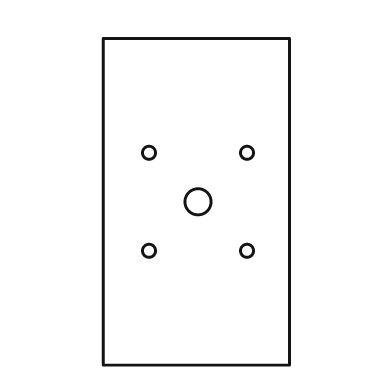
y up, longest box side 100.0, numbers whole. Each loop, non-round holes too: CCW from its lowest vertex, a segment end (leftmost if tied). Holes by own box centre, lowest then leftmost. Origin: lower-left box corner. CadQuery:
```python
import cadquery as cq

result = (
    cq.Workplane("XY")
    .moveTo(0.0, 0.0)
    .lineTo(57.0, 0.0)
    .lineTo(57.0, 100.0)
    .lineTo(0.0, 100.0)
    .close()
    .moveTo(14.0, 35.0)
    .circle(2.0)
    .moveTo(44.0, 35.0)
    .circle(2.0)
    .moveTo(29.0, 50.0)
    .circle(4.0)
    .moveTo(14.0, 65.0)
    .circle(2.0)
    .moveTo(44.0, 65.0)
    .circle(2.0)
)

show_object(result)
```